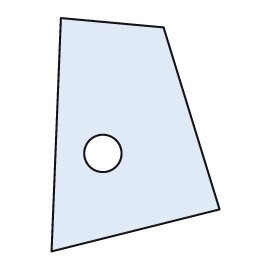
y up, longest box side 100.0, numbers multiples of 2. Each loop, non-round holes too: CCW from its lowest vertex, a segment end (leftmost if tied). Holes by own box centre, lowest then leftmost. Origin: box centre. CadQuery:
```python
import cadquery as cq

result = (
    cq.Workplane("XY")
    .moveTo(-36.0, -50.0)
    .lineTo(36.0, -32.0)
    .lineTo(12.0, 46.0)
    .lineTo(-32.0, 50.0)
    .close()
    .moveTo(-14.0, -8.0)
    .circle(8.0)
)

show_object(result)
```